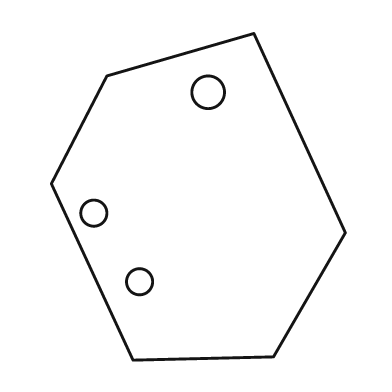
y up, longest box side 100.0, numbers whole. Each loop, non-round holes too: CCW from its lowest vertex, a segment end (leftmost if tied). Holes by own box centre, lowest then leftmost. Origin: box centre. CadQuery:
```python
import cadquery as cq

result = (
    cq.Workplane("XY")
    .moveTo(-20.0, -50.0)
    .lineTo(23.0, -49.0)
    .lineTo(45.0, -11.0)
    .lineTo(17.0, 50.0)
    .lineTo(-28.0, 37.0)
    .lineTo(-45.0, 4.0)
    .close()
    .moveTo(-18.0, -26.0)
    .circle(4.0)
    .moveTo(-32.0, -5.0)
    .circle(4.0)
    .moveTo(3.0, 32.0)
    .circle(5.0)
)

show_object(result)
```